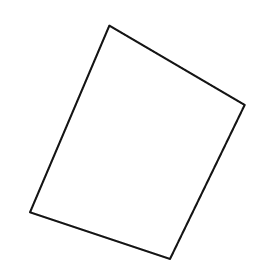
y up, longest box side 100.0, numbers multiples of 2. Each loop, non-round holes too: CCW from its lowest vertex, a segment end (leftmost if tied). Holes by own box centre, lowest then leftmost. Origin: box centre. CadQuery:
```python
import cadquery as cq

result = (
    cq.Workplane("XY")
    .moveTo(14.0, -50.0)
    .lineTo(46.0, 16.0)
    .lineTo(-12.0, 50.0)
    .lineTo(-46.0, -30.0)
    .close()
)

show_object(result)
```